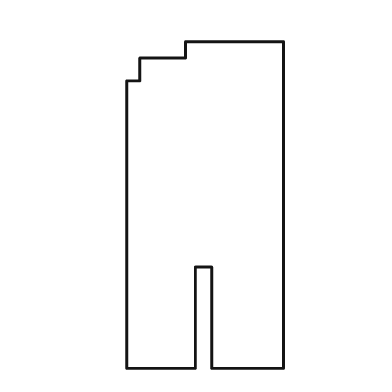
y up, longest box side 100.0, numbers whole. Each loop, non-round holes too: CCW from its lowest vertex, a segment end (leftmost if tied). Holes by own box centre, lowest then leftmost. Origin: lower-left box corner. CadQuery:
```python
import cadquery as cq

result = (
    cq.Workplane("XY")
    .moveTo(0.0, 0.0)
    .lineTo(21.0, 0.0)
    .lineTo(21.0, 31.0)
    .lineTo(26.0, 31.0)
    .lineTo(26.0, 0.0)
    .lineTo(48.0, 0.0)
    .lineTo(48.0, 100.0)
    .lineTo(18.0, 100.0)
    .lineTo(18.0, 95.0)
    .lineTo(4.0, 95.0)
    .lineTo(4.0, 88.0)
    .lineTo(0.0, 88.0)
    .close()
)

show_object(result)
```